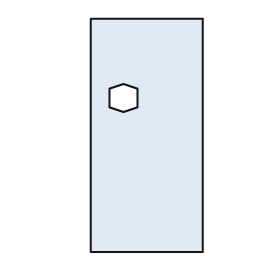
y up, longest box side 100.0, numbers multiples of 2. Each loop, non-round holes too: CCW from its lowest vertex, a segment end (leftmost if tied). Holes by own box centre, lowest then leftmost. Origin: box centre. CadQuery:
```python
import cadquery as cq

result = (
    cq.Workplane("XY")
    .moveTo(-24.0, -50.0)
    .lineTo(24.0, -50.0)
    .lineTo(24.0, 50.0)
    .lineTo(-24.0, 50.0)
    .close()
    .moveTo(-10.0, 10.0)
    .lineTo(-4.0, 12.0)
    .lineTo(-4.0, 20.0)
    .lineTo(-10.0, 22.0)
    .lineTo(-16.0, 20.0)
    .lineTo(-16.0, 12.0)
    .close()
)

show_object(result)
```